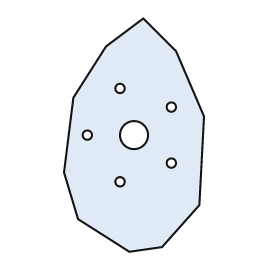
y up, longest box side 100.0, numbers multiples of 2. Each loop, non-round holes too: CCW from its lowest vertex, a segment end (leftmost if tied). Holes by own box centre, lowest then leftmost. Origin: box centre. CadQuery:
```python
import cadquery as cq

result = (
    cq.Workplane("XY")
    .moveTo(-2.0, -50.0)
    .lineTo(12.0, -48.0)
    .lineTo(28.0, -30.0)
    .lineTo(30.0, 8.0)
    .lineTo(18.0, 36.0)
    .lineTo(4.0, 50.0)
    .lineTo(-12.0, 38.0)
    .lineTo(-26.0, 16.0)
    .lineTo(-30.0, -16.0)
    .lineTo(-24.0, -36.0)
    .close()
    .moveTo(-6.0, -20.0)
    .circle(2.0)
    .moveTo(16.0, -12.0)
    .circle(2.0)
    .moveTo(-20.0, 0.0)
    .circle(2.0)
    .moveTo(0.0, 0.0)
    .circle(6.0)
    .moveTo(16.0, 12.0)
    .circle(2.0)
    .moveTo(-6.0, 20.0)
    .circle(2.0)
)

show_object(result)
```